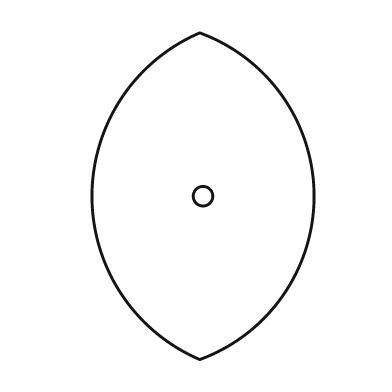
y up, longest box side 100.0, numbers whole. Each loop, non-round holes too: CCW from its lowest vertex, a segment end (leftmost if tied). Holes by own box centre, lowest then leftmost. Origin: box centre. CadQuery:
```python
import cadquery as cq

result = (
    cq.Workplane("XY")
    .moveTo(-1.0, -50.0)
    .threePointArc((34.0, 0.0), (-1.0, 50.0))
    .threePointArc((-34.0, 0.0), (-1.0, -50.0))
    .close()
    .moveTo(0.0, 0.0)
    .circle(3.0)
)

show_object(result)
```